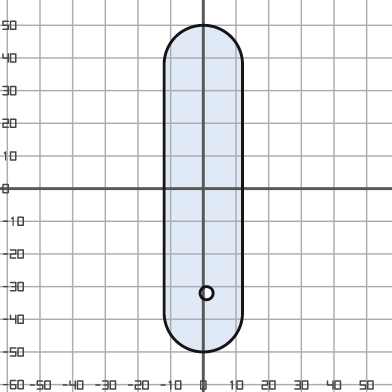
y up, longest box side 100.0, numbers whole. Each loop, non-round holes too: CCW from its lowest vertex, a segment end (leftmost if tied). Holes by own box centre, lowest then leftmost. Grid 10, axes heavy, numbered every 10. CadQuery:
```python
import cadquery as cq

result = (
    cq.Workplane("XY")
    .moveTo(-12.0, -38.0)
    .threePointArc((0.0, -50.0), (12.0, -38.0))
    .lineTo(12.0, 38.0)
    .threePointArc((0.0, 50.0), (-12.0, 38.0))
    .close()
    .moveTo(1.0, -32.0)
    .circle(2.0)
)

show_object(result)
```